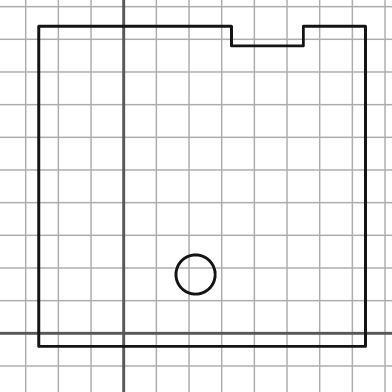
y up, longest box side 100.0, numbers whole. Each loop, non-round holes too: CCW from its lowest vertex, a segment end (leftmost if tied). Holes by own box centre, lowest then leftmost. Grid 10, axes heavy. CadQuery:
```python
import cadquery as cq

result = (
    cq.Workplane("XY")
    .moveTo(-26.0, -4.0)
    .lineTo(74.0, -4.0)
    .lineTo(74.0, 94.0)
    .lineTo(55.0, 94.0)
    .lineTo(55.0, 88.0)
    .lineTo(33.0, 88.0)
    .lineTo(33.0, 94.0)
    .lineTo(-26.0, 94.0)
    .close()
    .moveTo(22.0, 18.0)
    .circle(6.0)
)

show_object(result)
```